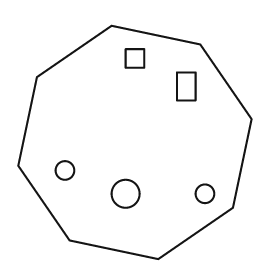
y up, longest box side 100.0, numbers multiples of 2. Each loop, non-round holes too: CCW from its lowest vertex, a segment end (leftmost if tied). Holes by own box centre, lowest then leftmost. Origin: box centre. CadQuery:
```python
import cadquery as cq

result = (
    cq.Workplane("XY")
    .moveTo(10.0, -50.0)
    .lineTo(42.0, -28.0)
    .lineTo(50.0, 10.0)
    .lineTo(28.0, 42.0)
    .lineTo(-10.0, 50.0)
    .lineTo(-42.0, 28.0)
    .lineTo(-50.0, -10.0)
    .lineTo(-28.0, -42.0)
    .close()
    .moveTo(-4.0, -22.0)
    .circle(6.0)
    .moveTo(30.0, -22.0)
    .circle(4.0)
    .moveTo(-30.0, -12.0)
    .circle(4.0)
    .moveTo(18.0, 18.0)
    .lineTo(26.0, 18.0)
    .lineTo(26.0, 30.0)
    .lineTo(18.0, 30.0)
    .close()
    .moveTo(-4.0, 32.0)
    .lineTo(4.0, 32.0)
    .lineTo(4.0, 40.0)
    .lineTo(-4.0, 40.0)
    .close()
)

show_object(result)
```